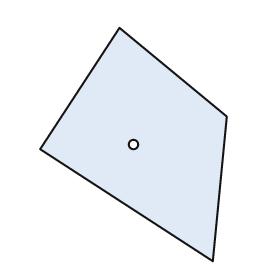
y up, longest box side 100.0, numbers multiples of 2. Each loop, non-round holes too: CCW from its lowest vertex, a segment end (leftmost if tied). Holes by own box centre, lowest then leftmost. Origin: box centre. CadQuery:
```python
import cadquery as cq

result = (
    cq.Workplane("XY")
    .moveTo(34.0, -50.0)
    .lineTo(40.0, 12.0)
    .lineTo(-6.0, 50.0)
    .lineTo(-40.0, -2.0)
    .close()
    .moveTo(0.0, 0.0)
    .circle(2.0)
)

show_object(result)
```